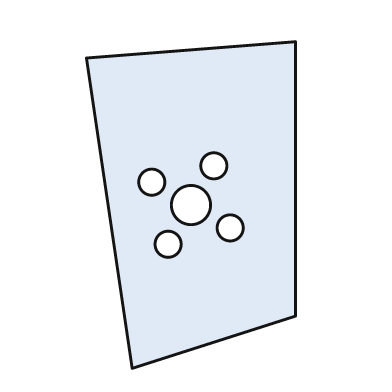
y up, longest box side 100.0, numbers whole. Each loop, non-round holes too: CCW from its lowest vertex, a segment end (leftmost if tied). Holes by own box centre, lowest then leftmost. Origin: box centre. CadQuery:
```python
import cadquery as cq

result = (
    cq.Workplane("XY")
    .moveTo(-18.0, -50.0)
    .lineTo(32.0, -34.0)
    .lineTo(32.0, 50.0)
    .lineTo(-32.0, 45.0)
    .close()
    .moveTo(-7.0, -12.0)
    .circle(4.0)
    .moveTo(12.0, -7.0)
    .circle(4.0)
    .moveTo(0.0, 0.0)
    .circle(6.0)
    .moveTo(-12.0, 7.0)
    .circle(4.0)
    .moveTo(7.0, 12.0)
    .circle(4.0)
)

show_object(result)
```